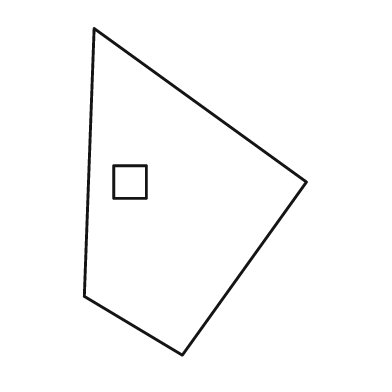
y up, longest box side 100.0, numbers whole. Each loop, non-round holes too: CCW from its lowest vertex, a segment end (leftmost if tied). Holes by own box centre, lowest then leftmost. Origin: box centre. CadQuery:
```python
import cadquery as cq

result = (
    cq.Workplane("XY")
    .moveTo(-4.0, -50.0)
    .lineTo(34.0, 3.0)
    .lineTo(-31.0, 50.0)
    .lineTo(-34.0, -32.0)
    .close()
    .moveTo(-25.0, -2.0)
    .lineTo(-15.0, -2.0)
    .lineTo(-15.0, 8.0)
    .lineTo(-25.0, 8.0)
    .close()
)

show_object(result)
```